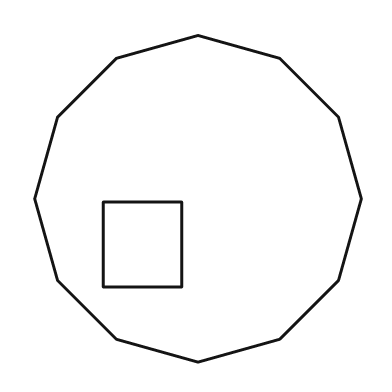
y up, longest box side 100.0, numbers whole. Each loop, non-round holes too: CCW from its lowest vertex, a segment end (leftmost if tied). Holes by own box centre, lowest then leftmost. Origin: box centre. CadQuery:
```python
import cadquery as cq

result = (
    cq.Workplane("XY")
    .moveTo(0.0, -50.0)
    .lineTo(25.0, -43.0)
    .lineTo(43.0, -25.0)
    .lineTo(50.0, 0.0)
    .lineTo(43.0, 25.0)
    .lineTo(25.0, 43.0)
    .lineTo(0.0, 50.0)
    .lineTo(-25.0, 43.0)
    .lineTo(-43.0, 25.0)
    .lineTo(-50.0, 0.0)
    .lineTo(-43.0, -25.0)
    .lineTo(-25.0, -43.0)
    .close()
    .moveTo(-29.0, -27.0)
    .lineTo(-5.0, -27.0)
    .lineTo(-5.0, -1.0)
    .lineTo(-29.0, -1.0)
    .close()
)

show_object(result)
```